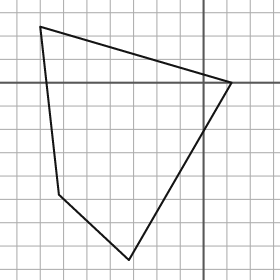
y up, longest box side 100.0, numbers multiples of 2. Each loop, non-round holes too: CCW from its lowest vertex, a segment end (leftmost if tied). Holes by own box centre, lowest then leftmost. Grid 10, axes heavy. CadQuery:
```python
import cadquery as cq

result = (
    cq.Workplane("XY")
    .moveTo(-32.0, -76.0)
    .lineTo(12.0, 0.0)
    .lineTo(-70.0, 24.0)
    .lineTo(-62.0, -48.0)
    .close()
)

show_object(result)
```